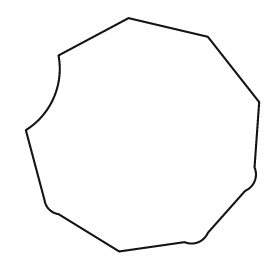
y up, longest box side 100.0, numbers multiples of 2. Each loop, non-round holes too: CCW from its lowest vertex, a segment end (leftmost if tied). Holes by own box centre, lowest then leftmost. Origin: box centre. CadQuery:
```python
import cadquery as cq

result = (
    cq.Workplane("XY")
    .moveTo(-10.0, -50.0)
    .lineTo(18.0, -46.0)
    .threePointArc((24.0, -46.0), (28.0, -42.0))
    .lineTo(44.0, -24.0)
    .threePointArc((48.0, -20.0), (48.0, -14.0))
    .lineTo(50.0, 14.0)
    .lineTo(28.0, 42.0)
    .lineTo(-6.0, 50.0)
    .lineTo(-36.0, 34.0)
    .threePointArc((-38.0, 16.0), (-50.0, 2.0))
    .lineTo(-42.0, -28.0)
    .threePointArc((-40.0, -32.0), (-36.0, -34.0))
    .close()
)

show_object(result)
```